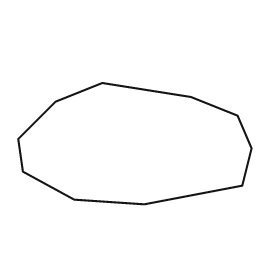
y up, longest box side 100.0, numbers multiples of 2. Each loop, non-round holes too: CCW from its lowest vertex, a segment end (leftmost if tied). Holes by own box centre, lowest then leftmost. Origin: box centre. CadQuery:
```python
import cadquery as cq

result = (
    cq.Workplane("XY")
    .moveTo(4.0, -26.0)
    .lineTo(46.0, -18.0)
    .lineTo(50.0, -2.0)
    .lineTo(44.0, 12.0)
    .lineTo(24.0, 20.0)
    .lineTo(-14.0, 26.0)
    .lineTo(-34.0, 18.0)
    .lineTo(-50.0, 2.0)
    .lineTo(-48.0, -12.0)
    .lineTo(-26.0, -24.0)
    .close()
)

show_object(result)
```